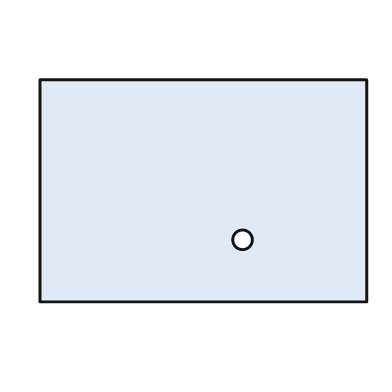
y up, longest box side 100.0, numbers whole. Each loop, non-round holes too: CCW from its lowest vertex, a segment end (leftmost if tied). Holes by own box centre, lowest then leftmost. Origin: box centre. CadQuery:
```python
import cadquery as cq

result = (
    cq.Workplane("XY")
    .moveTo(-50.0, -34.0)
    .lineTo(50.0, -34.0)
    .lineTo(50.0, 34.0)
    .lineTo(-50.0, 34.0)
    .close()
    .moveTo(12.0, -15.0)
    .circle(3.0)
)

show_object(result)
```